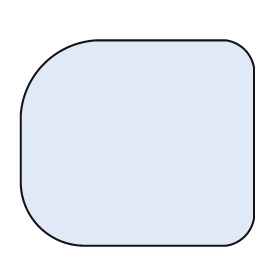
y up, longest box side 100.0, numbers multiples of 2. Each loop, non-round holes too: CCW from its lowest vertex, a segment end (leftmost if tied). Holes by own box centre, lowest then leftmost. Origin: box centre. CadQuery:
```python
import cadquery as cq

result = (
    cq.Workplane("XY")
    .moveTo(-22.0, -44.0)
    .lineTo(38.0, -44.0)
    .threePointArc((46.0, -40.0), (50.0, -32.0))
    .lineTo(50.0, 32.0)
    .threePointArc((46.0, 40.0), (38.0, 44.0))
    .lineTo(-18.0, 44.0)
    .threePointArc((-40.0, 34.0), (-50.0, 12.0))
    .lineTo(-50.0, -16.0)
    .threePointArc((-42.0, -36.0), (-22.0, -44.0))
    .close()
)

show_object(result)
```